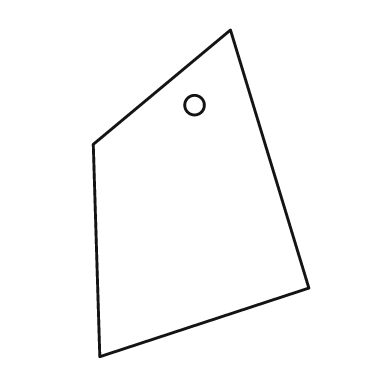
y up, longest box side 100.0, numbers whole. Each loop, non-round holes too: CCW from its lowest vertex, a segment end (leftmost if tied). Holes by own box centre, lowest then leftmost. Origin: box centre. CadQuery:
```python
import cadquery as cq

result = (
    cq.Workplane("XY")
    .moveTo(-31.0, -50.0)
    .lineTo(33.0, -29.0)
    .lineTo(9.0, 50.0)
    .lineTo(-33.0, 15.0)
    .close()
    .moveTo(-2.0, 27.0)
    .circle(3.0)
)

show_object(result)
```